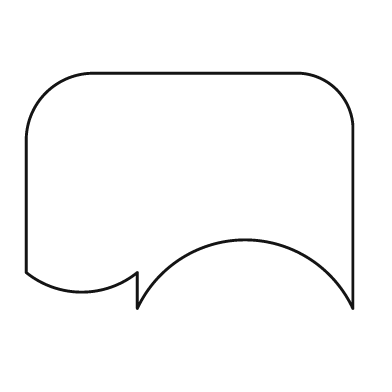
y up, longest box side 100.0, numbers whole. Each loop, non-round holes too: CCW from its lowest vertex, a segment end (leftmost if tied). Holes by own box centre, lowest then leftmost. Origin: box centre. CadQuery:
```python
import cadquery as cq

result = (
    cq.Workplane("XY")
    .moveTo(-16.0, -36.0)
    .threePointArc((17.0, -15.0), (50.0, -36.0))
    .lineTo(50.0, 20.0)
    .threePointArc((45.0, 31.0), (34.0, 36.0))
    .lineTo(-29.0, 36.0)
    .threePointArc((-44.0, 30.0), (-50.0, 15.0))
    .lineTo(-50.0, -25.0)
    .threePointArc((-33.0, -31.0), (-16.0, -25.0))
    .close()
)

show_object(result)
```